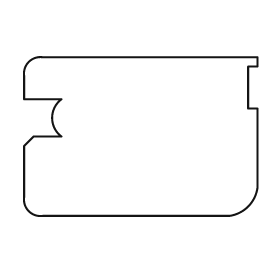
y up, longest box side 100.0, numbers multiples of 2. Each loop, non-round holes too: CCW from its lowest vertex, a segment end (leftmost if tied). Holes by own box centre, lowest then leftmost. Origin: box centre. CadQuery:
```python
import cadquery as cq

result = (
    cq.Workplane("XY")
    .moveTo(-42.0, -34.0)
    .lineTo(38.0, -34.0)
    .threePointArc((46.0, -30.0), (50.0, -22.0))
    .lineTo(50.0, 12.0)
    .lineTo(46.0, 12.0)
    .lineTo(46.0, 30.0)
    .lineTo(50.0, 30.0)
    .lineTo(50.0, 34.0)
    .lineTo(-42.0, 34.0)
    .threePointArc((-48.0, 32.0), (-50.0, 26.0))
    .lineTo(-50.0, 16.0)
    .lineTo(-34.0, 16.0)
    .threePointArc((-38.0, 8.0), (-34.0, 0.0))
    .lineTo(-46.0, 0.0)
    .lineTo(-50.0, -4.0)
    .lineTo(-50.0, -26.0)
    .threePointArc((-48.0, -32.0), (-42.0, -34.0))
    .close()
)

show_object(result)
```